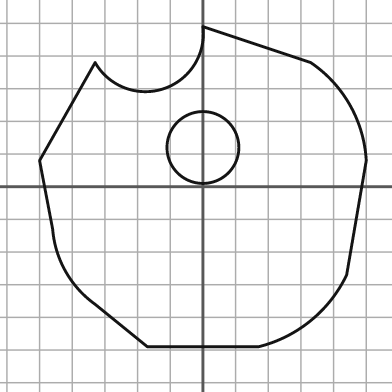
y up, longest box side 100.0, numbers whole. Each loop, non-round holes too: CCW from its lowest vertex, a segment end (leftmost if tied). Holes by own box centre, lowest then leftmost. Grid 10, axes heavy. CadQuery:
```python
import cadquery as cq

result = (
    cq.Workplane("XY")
    .moveTo(-17.0, -49.0)
    .lineTo(17.0, -49.0)
    .threePointArc((33.0, -41.0), (44.0, -27.0))
    .lineTo(50.0, 8.0)
    .threePointArc((45.0, 25.0), (33.0, 38.0))
    .lineTo(0.0, 49.0)
    .threePointArc((-12.0, 30.0), (-33.0, 38.0))
    .lineTo(-50.0, 8.0)
    .lineTo(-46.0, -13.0)
    .threePointArc((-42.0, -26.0), (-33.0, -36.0))
    .close()
    .moveTo(0.0, 12.0)
    .circle(11.0)
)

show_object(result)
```